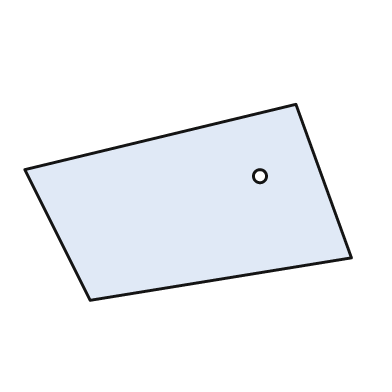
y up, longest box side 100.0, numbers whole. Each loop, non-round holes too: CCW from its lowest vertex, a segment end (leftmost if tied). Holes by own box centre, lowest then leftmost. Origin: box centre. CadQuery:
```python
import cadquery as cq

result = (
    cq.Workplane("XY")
    .moveTo(-30.0, -30.0)
    .lineTo(50.0, -17.0)
    .lineTo(33.0, 30.0)
    .lineTo(-50.0, 10.0)
    .close()
    .moveTo(22.0, 8.0)
    .circle(2.0)
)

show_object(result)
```